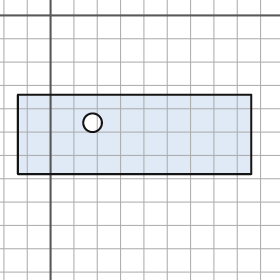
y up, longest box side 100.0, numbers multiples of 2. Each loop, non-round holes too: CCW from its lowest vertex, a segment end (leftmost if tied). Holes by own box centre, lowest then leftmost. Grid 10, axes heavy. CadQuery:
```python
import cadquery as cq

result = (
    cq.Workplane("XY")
    .moveTo(-14.0, -68.0)
    .lineTo(86.0, -68.0)
    .lineTo(86.0, -34.0)
    .lineTo(-14.0, -34.0)
    .close()
    .moveTo(18.0, -46.0)
    .circle(4.0)
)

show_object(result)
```